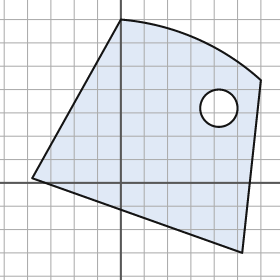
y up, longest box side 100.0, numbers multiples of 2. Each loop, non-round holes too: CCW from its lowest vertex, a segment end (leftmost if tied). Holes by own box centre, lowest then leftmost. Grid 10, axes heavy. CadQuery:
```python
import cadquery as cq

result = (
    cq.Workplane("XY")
    .moveTo(52.0, -30.0)
    .lineTo(60.0, 44.0)
    .threePointArc((32.0, 62.0), (0.0, 70.0))
    .lineTo(-38.0, 2.0)
    .close()
    .moveTo(42.0, 32.0)
    .circle(8.0)
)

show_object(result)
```